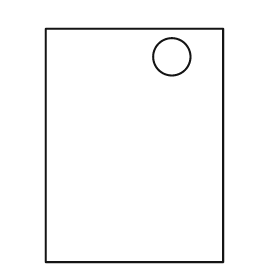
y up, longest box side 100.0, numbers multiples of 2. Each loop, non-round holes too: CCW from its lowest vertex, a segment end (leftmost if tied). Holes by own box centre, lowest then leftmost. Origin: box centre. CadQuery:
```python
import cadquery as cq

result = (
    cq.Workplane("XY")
    .moveTo(-38.0, -50.0)
    .lineTo(38.0, -50.0)
    .lineTo(38.0, 50.0)
    .lineTo(-38.0, 50.0)
    .close()
    .moveTo(16.0, 38.0)
    .circle(8.0)
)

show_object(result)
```